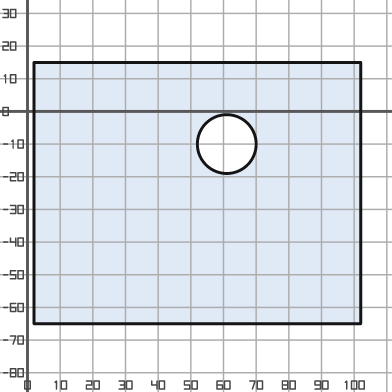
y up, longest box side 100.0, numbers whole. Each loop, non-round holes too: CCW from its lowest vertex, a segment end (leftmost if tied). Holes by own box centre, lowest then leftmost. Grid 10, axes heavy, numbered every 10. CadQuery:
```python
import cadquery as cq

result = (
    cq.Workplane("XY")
    .moveTo(2.0, -65.0)
    .lineTo(102.0, -65.0)
    .lineTo(102.0, 15.0)
    .lineTo(2.0, 15.0)
    .close()
    .moveTo(61.0, -10.0)
    .circle(9.0)
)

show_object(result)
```